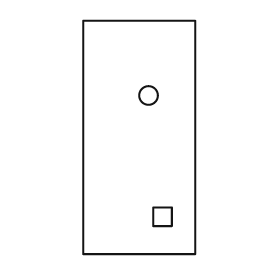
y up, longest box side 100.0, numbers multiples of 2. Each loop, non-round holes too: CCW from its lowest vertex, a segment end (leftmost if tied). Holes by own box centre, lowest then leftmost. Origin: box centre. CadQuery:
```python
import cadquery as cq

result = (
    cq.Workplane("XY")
    .moveTo(-24.0, -50.0)
    .lineTo(24.0, -50.0)
    .lineTo(24.0, 50.0)
    .lineTo(-24.0, 50.0)
    .close()
    .moveTo(6.0, -38.0)
    .lineTo(14.0, -38.0)
    .lineTo(14.0, -30.0)
    .lineTo(6.0, -30.0)
    .close()
    .moveTo(4.0, 18.0)
    .circle(4.0)
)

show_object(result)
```